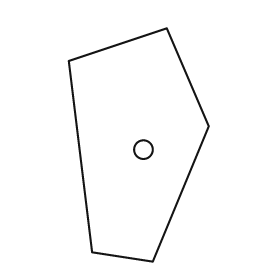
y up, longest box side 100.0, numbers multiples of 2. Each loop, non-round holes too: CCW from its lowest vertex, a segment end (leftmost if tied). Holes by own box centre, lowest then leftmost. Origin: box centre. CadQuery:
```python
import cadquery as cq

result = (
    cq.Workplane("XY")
    .moveTo(6.0, -50.0)
    .lineTo(30.0, 8.0)
    .lineTo(12.0, 50.0)
    .lineTo(-30.0, 36.0)
    .lineTo(-20.0, -46.0)
    .close()
    .moveTo(2.0, -2.0)
    .circle(4.0)
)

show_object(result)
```